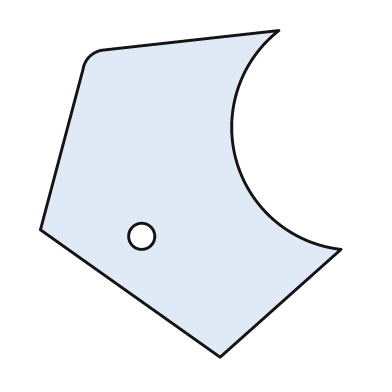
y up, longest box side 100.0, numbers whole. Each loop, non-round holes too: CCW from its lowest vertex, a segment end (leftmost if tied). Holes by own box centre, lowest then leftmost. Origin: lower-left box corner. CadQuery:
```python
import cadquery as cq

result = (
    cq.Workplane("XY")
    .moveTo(55.0, 0.0)
    .lineTo(92.0, 33.0)
    .threePointArc((60.0, 60.0), (73.0, 100.0))
    .lineTo(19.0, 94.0)
    .threePointArc((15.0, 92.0), (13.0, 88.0))
    .lineTo(0.0, 39.0)
    .close()
    .moveTo(31.0, 37.0)
    .circle(4.0)
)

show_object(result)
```